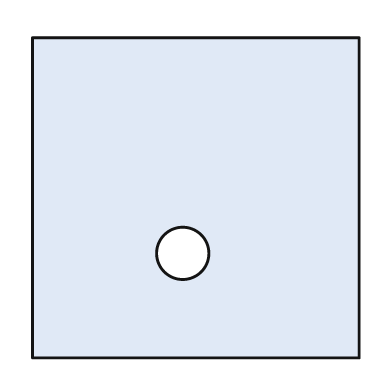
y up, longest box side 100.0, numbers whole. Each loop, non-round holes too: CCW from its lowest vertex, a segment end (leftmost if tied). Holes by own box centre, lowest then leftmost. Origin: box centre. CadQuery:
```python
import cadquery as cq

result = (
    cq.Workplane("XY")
    .moveTo(-50.0, -49.0)
    .lineTo(50.0, -49.0)
    .lineTo(50.0, 49.0)
    .lineTo(-50.0, 49.0)
    .close()
    .moveTo(-4.0, -17.0)
    .circle(8.0)
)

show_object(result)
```